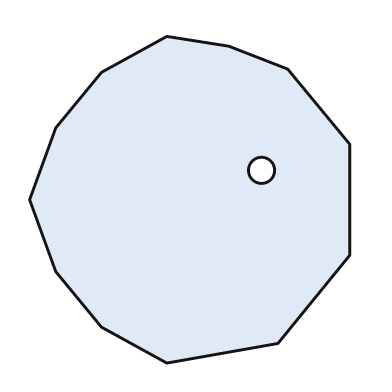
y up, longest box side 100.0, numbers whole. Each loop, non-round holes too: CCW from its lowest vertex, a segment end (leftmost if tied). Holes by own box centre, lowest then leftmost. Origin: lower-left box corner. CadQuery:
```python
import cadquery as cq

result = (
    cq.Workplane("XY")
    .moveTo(42.0, 0.0)
    .lineTo(76.0, 6.0)
    .lineTo(98.0, 33.0)
    .lineTo(98.0, 67.0)
    .lineTo(79.0, 90.0)
    .lineTo(61.0, 97.0)
    .lineTo(42.0, 100.0)
    .lineTo(22.0, 89.0)
    .lineTo(8.0, 72.0)
    .lineTo(0.0, 50.0)
    .lineTo(8.0, 28.0)
    .lineTo(22.0, 11.0)
    .close()
    .moveTo(71.0, 59.0)
    .circle(4.0)
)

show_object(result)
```